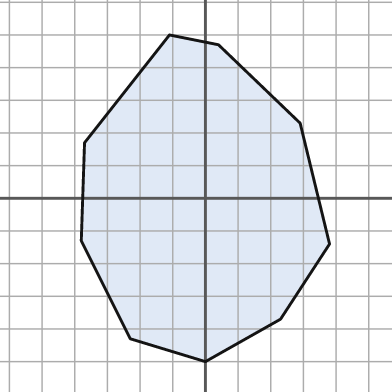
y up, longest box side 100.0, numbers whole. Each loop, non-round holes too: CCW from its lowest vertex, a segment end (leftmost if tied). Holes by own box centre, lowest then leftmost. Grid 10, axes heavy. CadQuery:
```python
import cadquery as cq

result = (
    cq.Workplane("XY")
    .moveTo(0.0, -50.0)
    .lineTo(23.0, -37.0)
    .lineTo(38.0, -14.0)
    .lineTo(29.0, 23.0)
    .lineTo(4.0, 47.0)
    .lineTo(-11.0, 50.0)
    .lineTo(-37.0, 17.0)
    .lineTo(-38.0, -13.0)
    .lineTo(-23.0, -43.0)
    .close()
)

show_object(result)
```